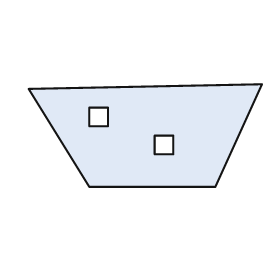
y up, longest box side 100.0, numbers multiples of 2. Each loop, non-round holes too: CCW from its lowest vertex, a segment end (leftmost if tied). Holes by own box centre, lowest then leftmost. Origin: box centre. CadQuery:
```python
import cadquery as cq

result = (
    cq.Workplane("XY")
    .moveTo(-24.0, -22.0)
    .lineTo(30.0, -22.0)
    .lineTo(50.0, 22.0)
    .lineTo(-50.0, 20.0)
    .close()
    .moveTo(4.0, -8.0)
    .lineTo(12.0, -8.0)
    .lineTo(12.0, 0.0)
    .lineTo(4.0, 0.0)
    .close()
    .moveTo(-24.0, 4.0)
    .lineTo(-16.0, 4.0)
    .lineTo(-16.0, 12.0)
    .lineTo(-24.0, 12.0)
    .close()
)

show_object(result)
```